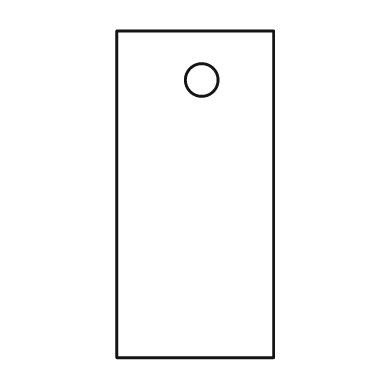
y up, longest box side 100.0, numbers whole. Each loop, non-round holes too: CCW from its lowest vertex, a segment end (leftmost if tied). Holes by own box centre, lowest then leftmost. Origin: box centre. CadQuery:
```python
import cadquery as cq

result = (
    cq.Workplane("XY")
    .moveTo(-24.0, -50.0)
    .lineTo(24.0, -50.0)
    .lineTo(24.0, 50.0)
    .lineTo(-24.0, 50.0)
    .close()
    .moveTo(2.0, 35.0)
    .circle(5.0)
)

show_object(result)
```